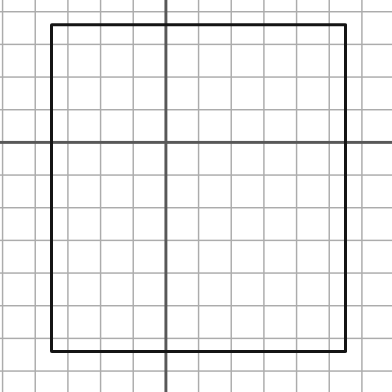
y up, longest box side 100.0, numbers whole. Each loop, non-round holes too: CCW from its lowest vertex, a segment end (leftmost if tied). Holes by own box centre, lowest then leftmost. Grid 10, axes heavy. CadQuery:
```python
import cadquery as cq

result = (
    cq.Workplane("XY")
    .moveTo(-35.0, -64.0)
    .lineTo(55.0, -64.0)
    .lineTo(55.0, 36.0)
    .lineTo(-35.0, 36.0)
    .close()
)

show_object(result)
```